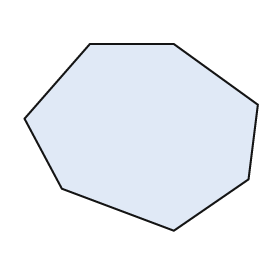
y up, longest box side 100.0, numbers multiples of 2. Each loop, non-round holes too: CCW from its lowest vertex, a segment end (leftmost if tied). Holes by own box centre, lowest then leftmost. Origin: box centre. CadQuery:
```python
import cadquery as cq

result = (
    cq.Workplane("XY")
    .moveTo(14.0, -40.0)
    .lineTo(46.0, -18.0)
    .lineTo(50.0, 14.0)
    .lineTo(14.0, 40.0)
    .lineTo(-22.0, 40.0)
    .lineTo(-50.0, 8.0)
    .lineTo(-34.0, -22.0)
    .close()
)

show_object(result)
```